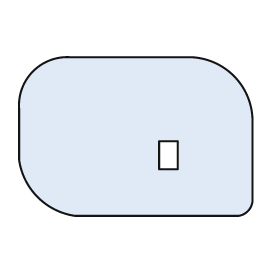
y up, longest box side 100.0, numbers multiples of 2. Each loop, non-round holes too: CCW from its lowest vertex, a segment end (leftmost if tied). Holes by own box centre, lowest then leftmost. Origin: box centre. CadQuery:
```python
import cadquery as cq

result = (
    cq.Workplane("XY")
    .moveTo(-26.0, -34.0)
    .lineTo(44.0, -34.0)
    .threePointArc((48.0, -32.0), (50.0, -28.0))
    .lineTo(50.0, 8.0)
    .threePointArc((42.0, 26.0), (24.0, 34.0))
    .lineTo(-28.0, 34.0)
    .threePointArc((-44.0, 28.0), (-50.0, 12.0))
    .lineTo(-50.0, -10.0)
    .threePointArc((-42.0, -26.0), (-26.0, -34.0))
    .close()
    .moveTo(10.0, -14.0)
    .lineTo(18.0, -14.0)
    .lineTo(18.0, -2.0)
    .lineTo(10.0, -2.0)
    .close()
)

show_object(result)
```